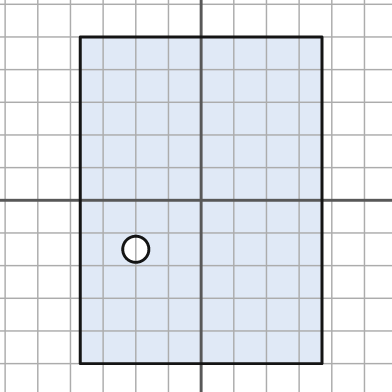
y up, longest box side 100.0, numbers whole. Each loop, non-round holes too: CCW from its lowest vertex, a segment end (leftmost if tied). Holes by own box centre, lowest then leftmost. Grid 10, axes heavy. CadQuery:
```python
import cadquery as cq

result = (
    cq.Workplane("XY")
    .moveTo(-37.0, -50.0)
    .lineTo(37.0, -50.0)
    .lineTo(37.0, 50.0)
    .lineTo(-37.0, 50.0)
    .close()
    .moveTo(-20.0, -15.0)
    .circle(4.0)
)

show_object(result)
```